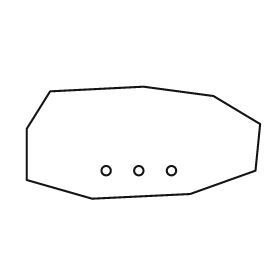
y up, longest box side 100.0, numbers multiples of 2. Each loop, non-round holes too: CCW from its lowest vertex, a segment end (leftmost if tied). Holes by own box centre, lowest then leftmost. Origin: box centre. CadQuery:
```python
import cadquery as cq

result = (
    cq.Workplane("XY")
    .moveTo(-22.0, -24.0)
    .lineTo(20.0, -22.0)
    .lineTo(48.0, -12.0)
    .lineTo(50.0, 8.0)
    .lineTo(30.0, 20.0)
    .lineTo(0.0, 24.0)
    .lineTo(-40.0, 22.0)
    .lineTo(-50.0, 6.0)
    .lineTo(-50.0, -16.0)
    .close()
    .moveTo(-16.0, -12.0)
    .circle(2.0)
    .moveTo(-2.0, -12.0)
    .circle(2.0)
    .moveTo(12.0, -12.0)
    .circle(2.0)
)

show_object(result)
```